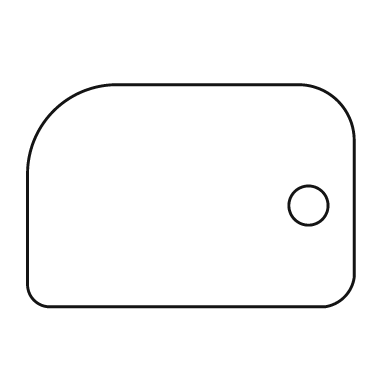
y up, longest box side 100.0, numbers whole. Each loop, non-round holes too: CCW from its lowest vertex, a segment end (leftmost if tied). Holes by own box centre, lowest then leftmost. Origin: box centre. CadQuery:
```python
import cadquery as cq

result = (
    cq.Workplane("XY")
    .moveTo(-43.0, -34.0)
    .lineTo(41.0, -34.0)
    .threePointArc((47.0, -31.0), (50.0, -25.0))
    .lineTo(50.0, 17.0)
    .threePointArc((45.0, 29.0), (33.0, 34.0))
    .lineTo(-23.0, 34.0)
    .threePointArc((-42.0, 26.0), (-50.0, 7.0))
    .lineTo(-50.0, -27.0)
    .threePointArc((-48.0, -32.0), (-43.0, -34.0))
    .close()
    .moveTo(36.0, -3.0)
    .circle(6.0)
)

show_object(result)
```